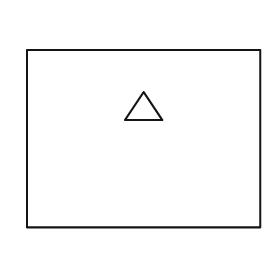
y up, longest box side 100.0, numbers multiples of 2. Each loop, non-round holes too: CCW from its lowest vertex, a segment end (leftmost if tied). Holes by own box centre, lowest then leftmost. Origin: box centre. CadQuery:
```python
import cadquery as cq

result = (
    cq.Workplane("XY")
    .moveTo(-50.0, -38.0)
    .lineTo(50.0, -38.0)
    .lineTo(50.0, 38.0)
    .lineTo(-50.0, 38.0)
    .close()
    .moveTo(-8.0, 8.0)
    .lineTo(8.0, 8.0)
    .lineTo(0.0, 20.0)
    .close()
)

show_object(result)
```